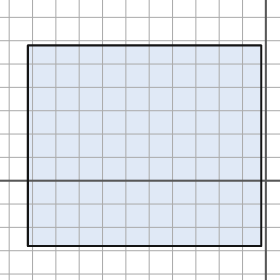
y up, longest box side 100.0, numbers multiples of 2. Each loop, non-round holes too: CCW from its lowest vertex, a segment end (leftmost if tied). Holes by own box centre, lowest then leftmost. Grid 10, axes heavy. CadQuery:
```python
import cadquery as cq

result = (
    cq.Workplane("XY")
    .moveTo(-102.0, -28.0)
    .lineTo(-2.0, -28.0)
    .lineTo(-2.0, 58.0)
    .lineTo(-102.0, 58.0)
    .close()
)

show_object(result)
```